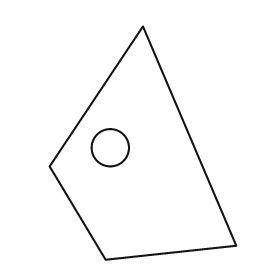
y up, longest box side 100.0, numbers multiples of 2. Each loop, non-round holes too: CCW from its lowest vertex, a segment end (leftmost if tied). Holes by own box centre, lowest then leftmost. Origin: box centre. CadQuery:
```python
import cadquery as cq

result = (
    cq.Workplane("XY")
    .moveTo(-16.0, -50.0)
    .lineTo(40.0, -44.0)
    .lineTo(0.0, 50.0)
    .lineTo(-40.0, -10.0)
    .close()
    .moveTo(-14.0, -2.0)
    .circle(8.0)
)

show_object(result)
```